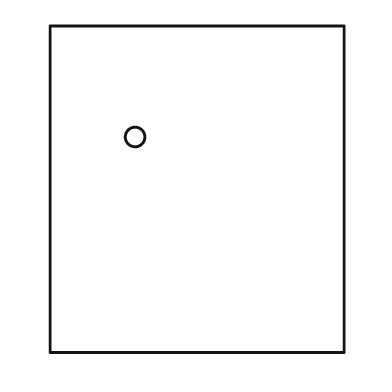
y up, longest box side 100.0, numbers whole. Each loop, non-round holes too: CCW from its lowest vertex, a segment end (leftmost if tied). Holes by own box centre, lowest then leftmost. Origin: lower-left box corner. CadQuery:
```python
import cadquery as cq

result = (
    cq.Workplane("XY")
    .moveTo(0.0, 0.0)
    .lineTo(90.0, 0.0)
    .lineTo(90.0, 100.0)
    .lineTo(0.0, 100.0)
    .close()
    .moveTo(26.0, 66.0)
    .circle(3.0)
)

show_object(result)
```